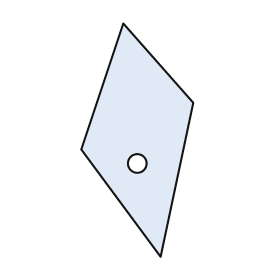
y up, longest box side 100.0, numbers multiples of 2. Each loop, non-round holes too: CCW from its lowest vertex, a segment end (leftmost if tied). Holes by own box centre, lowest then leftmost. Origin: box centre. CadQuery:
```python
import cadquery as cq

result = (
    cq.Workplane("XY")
    .moveTo(10.0, -50.0)
    .lineTo(24.0, 16.0)
    .lineTo(-6.0, 50.0)
    .lineTo(-24.0, -4.0)
    .close()
    .moveTo(0.0, -10.0)
    .circle(4.0)
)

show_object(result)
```